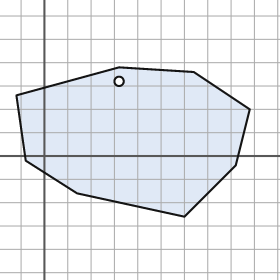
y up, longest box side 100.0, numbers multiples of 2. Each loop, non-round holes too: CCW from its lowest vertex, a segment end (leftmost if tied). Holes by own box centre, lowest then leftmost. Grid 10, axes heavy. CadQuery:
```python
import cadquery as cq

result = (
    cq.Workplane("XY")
    .moveTo(60.0, -26.0)
    .lineTo(82.0, -4.0)
    .lineTo(88.0, 20.0)
    .lineTo(64.0, 36.0)
    .lineTo(32.0, 38.0)
    .lineTo(-12.0, 26.0)
    .lineTo(-8.0, -2.0)
    .lineTo(14.0, -16.0)
    .close()
    .moveTo(32.0, 32.0)
    .circle(2.0)
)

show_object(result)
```